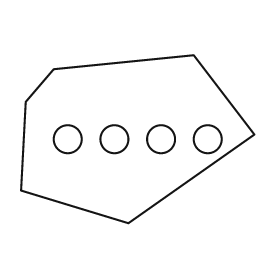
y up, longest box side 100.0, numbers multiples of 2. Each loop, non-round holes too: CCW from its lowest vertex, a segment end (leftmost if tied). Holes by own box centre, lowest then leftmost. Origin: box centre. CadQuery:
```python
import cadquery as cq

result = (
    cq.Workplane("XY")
    .moveTo(-4.0, -36.0)
    .lineTo(50.0, 2.0)
    .lineTo(24.0, 36.0)
    .lineTo(-36.0, 30.0)
    .lineTo(-48.0, 16.0)
    .lineTo(-50.0, -22.0)
    .close()
    .moveTo(-30.0, 0.0)
    .circle(6.0)
    .moveTo(-10.0, 0.0)
    .circle(6.0)
    .moveTo(10.0, 0.0)
    .circle(6.0)
    .moveTo(30.0, 0.0)
    .circle(6.0)
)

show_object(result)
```